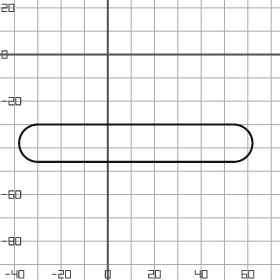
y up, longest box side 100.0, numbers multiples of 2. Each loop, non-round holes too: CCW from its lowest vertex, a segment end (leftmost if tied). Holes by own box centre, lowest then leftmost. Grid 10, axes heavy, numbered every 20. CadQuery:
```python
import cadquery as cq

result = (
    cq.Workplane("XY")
    .moveTo(-30.0, -46.0)
    .lineTo(54.0, -46.0)
    .threePointArc((62.0, -38.0), (54.0, -30.0))
    .lineTo(-30.0, -30.0)
    .threePointArc((-38.0, -38.0), (-30.0, -46.0))
    .close()
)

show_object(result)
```